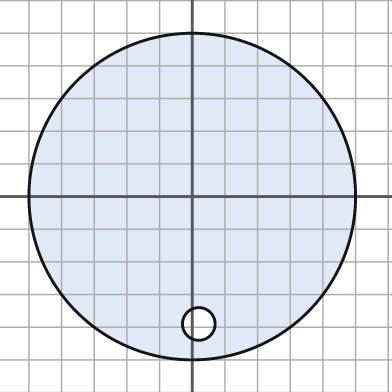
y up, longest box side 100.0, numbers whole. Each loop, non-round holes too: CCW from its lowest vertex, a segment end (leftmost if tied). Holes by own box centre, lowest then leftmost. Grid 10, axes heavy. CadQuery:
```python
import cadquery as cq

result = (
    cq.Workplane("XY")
    .moveTo(0.0, 0.0)
    .circle(50.0)
    .moveTo(2.0, -39.0)
    .circle(5.0)
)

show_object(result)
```